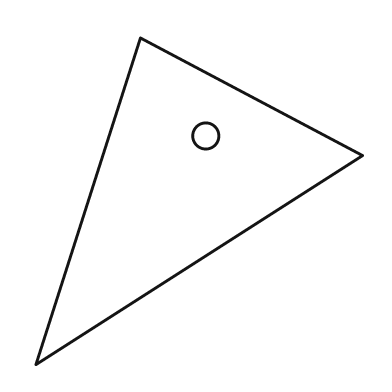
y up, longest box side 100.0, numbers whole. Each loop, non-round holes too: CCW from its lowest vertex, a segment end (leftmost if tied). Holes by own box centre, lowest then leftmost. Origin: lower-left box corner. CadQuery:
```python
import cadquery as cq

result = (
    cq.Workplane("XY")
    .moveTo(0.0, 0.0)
    .lineTo(100.0, 64.0)
    .lineTo(32.0, 100.0)
    .close()
    .moveTo(52.0, 70.0)
    .circle(4.0)
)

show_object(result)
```